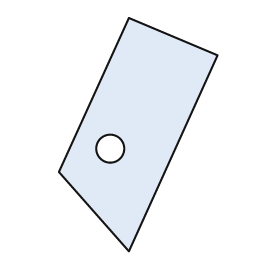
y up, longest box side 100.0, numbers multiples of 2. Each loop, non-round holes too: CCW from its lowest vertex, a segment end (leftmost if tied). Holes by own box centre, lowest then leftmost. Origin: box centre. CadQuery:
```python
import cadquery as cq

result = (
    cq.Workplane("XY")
    .moveTo(-4.0, -50.0)
    .lineTo(34.0, 34.0)
    .lineTo(-4.0, 50.0)
    .lineTo(-34.0, -16.0)
    .close()
    .moveTo(-12.0, -6.0)
    .circle(6.0)
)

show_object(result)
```